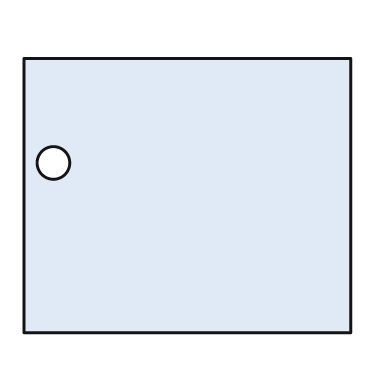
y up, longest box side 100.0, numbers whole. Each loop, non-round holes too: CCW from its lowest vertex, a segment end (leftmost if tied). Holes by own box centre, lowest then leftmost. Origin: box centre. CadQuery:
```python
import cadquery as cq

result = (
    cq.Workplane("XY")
    .moveTo(-50.0, -42.0)
    .lineTo(50.0, -42.0)
    .lineTo(50.0, 42.0)
    .lineTo(-50.0, 42.0)
    .close()
    .moveTo(-41.0, 10.0)
    .circle(5.0)
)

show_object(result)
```